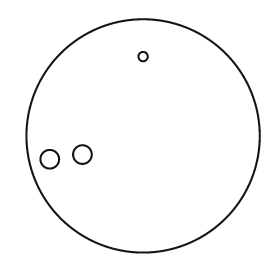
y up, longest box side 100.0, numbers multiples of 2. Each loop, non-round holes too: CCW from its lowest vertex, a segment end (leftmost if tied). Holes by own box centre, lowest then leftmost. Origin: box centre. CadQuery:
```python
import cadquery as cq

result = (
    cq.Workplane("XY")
    .moveTo(0.0, 0.0)
    .circle(50.0)
    .moveTo(-40.0, -10.0)
    .circle(4.0)
    .moveTo(-26.0, -8.0)
    .circle(4.0)
    .moveTo(0.0, 34.0)
    .circle(2.0)
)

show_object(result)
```